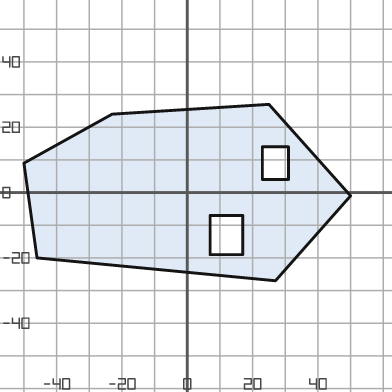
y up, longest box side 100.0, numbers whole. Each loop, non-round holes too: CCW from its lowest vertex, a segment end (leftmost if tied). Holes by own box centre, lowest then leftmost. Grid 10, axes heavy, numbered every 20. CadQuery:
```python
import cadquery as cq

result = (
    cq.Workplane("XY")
    .moveTo(27.0, -27.0)
    .lineTo(50.0, -1.0)
    .lineTo(25.0, 27.0)
    .lineTo(-23.0, 24.0)
    .lineTo(-50.0, 9.0)
    .lineTo(-46.0, -20.0)
    .close()
    .moveTo(7.0, -19.0)
    .lineTo(17.0, -19.0)
    .lineTo(17.0, -7.0)
    .lineTo(7.0, -7.0)
    .close()
    .moveTo(23.0, 4.0)
    .lineTo(31.0, 4.0)
    .lineTo(31.0, 14.0)
    .lineTo(23.0, 14.0)
    .close()
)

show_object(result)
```